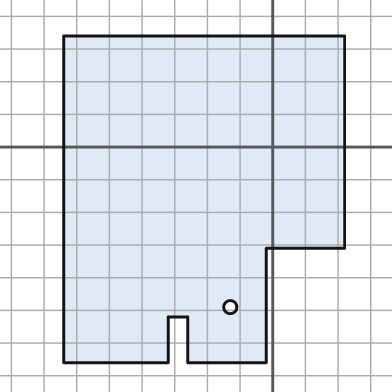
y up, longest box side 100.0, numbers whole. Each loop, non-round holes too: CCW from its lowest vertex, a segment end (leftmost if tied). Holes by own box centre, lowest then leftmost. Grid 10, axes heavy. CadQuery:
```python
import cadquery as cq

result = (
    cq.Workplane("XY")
    .moveTo(-64.0, -66.0)
    .lineTo(-32.0, -66.0)
    .lineTo(-32.0, -52.0)
    .lineTo(-26.0, -52.0)
    .lineTo(-26.0, -66.0)
    .lineTo(-2.0, -66.0)
    .lineTo(-2.0, -31.0)
    .lineTo(22.0, -31.0)
    .lineTo(22.0, 34.0)
    .lineTo(-64.0, 34.0)
    .close()
    .moveTo(-13.0, -49.0)
    .circle(2.0)
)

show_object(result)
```